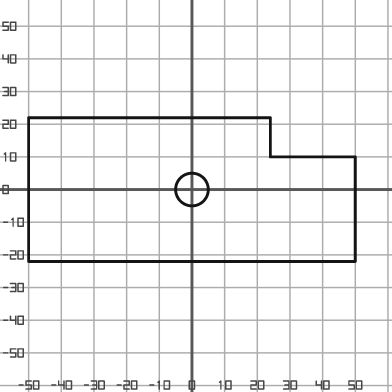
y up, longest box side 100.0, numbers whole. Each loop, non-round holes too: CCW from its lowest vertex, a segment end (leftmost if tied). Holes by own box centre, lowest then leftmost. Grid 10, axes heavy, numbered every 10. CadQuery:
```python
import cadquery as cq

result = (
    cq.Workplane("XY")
    .moveTo(-50.0, -22.0)
    .lineTo(50.0, -22.0)
    .lineTo(50.0, 10.0)
    .lineTo(24.0, 10.0)
    .lineTo(24.0, 22.0)
    .lineTo(-50.0, 22.0)
    .close()
    .moveTo(0.0, 0.0)
    .circle(5.0)
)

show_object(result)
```